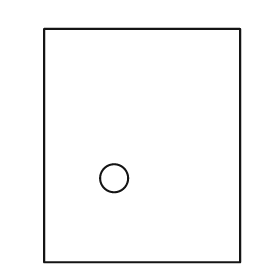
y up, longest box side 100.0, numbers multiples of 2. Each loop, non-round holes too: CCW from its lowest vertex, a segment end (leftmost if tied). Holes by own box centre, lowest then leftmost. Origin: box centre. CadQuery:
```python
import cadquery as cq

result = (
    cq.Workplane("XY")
    .moveTo(-42.0, -50.0)
    .lineTo(42.0, -50.0)
    .lineTo(42.0, 50.0)
    .lineTo(-42.0, 50.0)
    .close()
    .moveTo(-12.0, -14.0)
    .circle(6.0)
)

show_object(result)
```